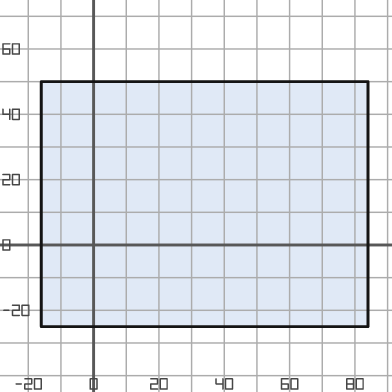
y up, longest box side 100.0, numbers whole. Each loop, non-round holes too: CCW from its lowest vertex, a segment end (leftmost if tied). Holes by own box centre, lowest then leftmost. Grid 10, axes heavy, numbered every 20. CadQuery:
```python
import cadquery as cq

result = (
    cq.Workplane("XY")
    .moveTo(-16.0, -25.0)
    .lineTo(84.0, -25.0)
    .lineTo(84.0, 50.0)
    .lineTo(-16.0, 50.0)
    .close()
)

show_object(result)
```